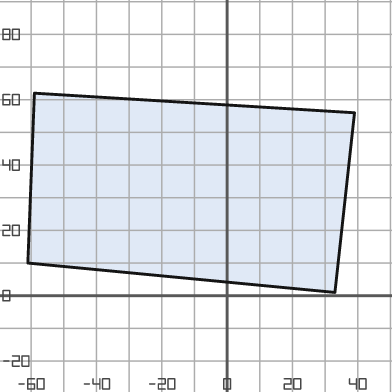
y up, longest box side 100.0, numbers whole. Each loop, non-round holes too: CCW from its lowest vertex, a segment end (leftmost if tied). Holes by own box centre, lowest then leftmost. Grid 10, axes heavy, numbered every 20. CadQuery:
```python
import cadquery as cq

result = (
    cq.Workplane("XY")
    .moveTo(33.0, 1.0)
    .lineTo(39.0, 56.0)
    .lineTo(-59.0, 62.0)
    .lineTo(-61.0, 10.0)
    .close()
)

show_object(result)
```